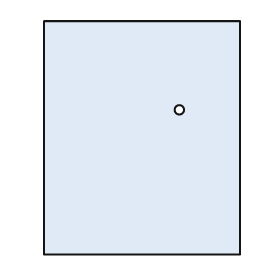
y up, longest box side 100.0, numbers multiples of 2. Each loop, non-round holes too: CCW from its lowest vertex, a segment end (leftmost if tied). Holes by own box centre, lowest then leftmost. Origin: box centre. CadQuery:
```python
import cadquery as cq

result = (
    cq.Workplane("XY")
    .moveTo(-42.0, -50.0)
    .lineTo(42.0, -50.0)
    .lineTo(42.0, 50.0)
    .lineTo(-42.0, 50.0)
    .close()
    .moveTo(16.0, 12.0)
    .circle(2.0)
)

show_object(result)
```